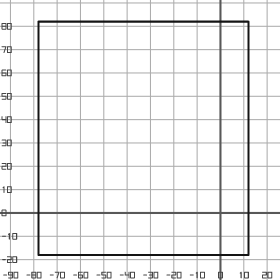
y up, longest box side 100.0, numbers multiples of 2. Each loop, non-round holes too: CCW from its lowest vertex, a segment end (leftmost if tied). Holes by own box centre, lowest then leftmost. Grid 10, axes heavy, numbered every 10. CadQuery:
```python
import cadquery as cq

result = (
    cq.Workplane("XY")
    .moveTo(-78.0, -18.0)
    .lineTo(12.0, -18.0)
    .lineTo(12.0, 82.0)
    .lineTo(-78.0, 82.0)
    .close()
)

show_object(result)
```